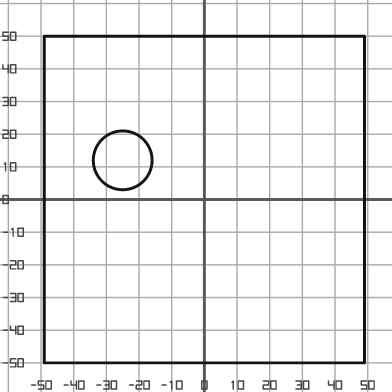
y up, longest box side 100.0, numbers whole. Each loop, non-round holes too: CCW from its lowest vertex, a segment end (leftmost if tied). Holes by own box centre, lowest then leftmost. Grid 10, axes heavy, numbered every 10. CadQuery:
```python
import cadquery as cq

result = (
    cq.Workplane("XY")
    .moveTo(-49.0, -50.0)
    .lineTo(49.0, -50.0)
    .lineTo(49.0, 50.0)
    .lineTo(-49.0, 50.0)
    .close()
    .moveTo(-25.0, 12.0)
    .circle(9.0)
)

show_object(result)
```